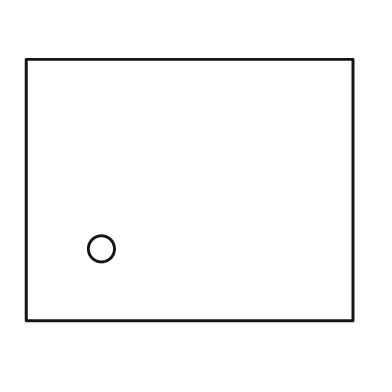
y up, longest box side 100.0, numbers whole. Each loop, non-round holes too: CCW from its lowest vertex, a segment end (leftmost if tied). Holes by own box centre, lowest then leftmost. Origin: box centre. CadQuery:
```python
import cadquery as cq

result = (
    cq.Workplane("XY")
    .moveTo(-50.0, -40.0)
    .lineTo(50.0, -40.0)
    .lineTo(50.0, 40.0)
    .lineTo(-50.0, 40.0)
    .close()
    .moveTo(-27.0, -18.0)
    .circle(4.0)
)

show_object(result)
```